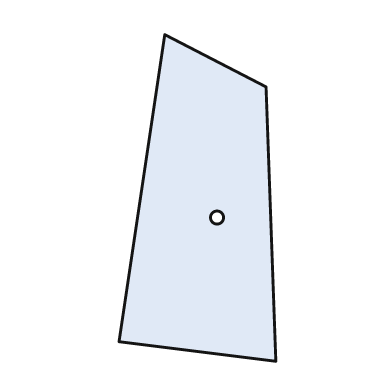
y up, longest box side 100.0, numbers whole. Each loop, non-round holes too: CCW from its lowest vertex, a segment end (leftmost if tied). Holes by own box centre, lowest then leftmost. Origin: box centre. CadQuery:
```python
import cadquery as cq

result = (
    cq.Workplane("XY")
    .moveTo(24.0, -50.0)
    .lineTo(21.0, 34.0)
    .lineTo(-10.0, 50.0)
    .lineTo(-24.0, -44.0)
    .close()
    .moveTo(6.0, -6.0)
    .circle(2.0)
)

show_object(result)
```